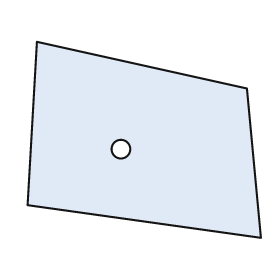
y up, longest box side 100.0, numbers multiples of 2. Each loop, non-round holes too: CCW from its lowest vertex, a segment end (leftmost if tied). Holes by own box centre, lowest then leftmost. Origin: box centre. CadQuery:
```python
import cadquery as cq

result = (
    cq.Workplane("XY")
    .moveTo(50.0, -42.0)
    .lineTo(44.0, 22.0)
    .lineTo(-46.0, 42.0)
    .lineTo(-50.0, -28.0)
    .close()
    .moveTo(-10.0, -4.0)
    .circle(4.0)
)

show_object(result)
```